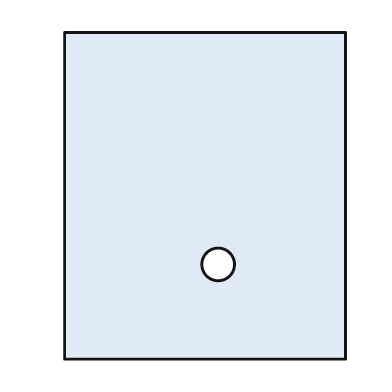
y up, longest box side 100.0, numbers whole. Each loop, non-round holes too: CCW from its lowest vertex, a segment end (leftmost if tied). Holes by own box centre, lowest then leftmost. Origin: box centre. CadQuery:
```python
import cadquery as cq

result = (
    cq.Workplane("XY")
    .moveTo(-43.0, -50.0)
    .lineTo(43.0, -50.0)
    .lineTo(43.0, 50.0)
    .lineTo(-43.0, 50.0)
    .close()
    .moveTo(4.0, -21.0)
    .circle(5.0)
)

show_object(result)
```